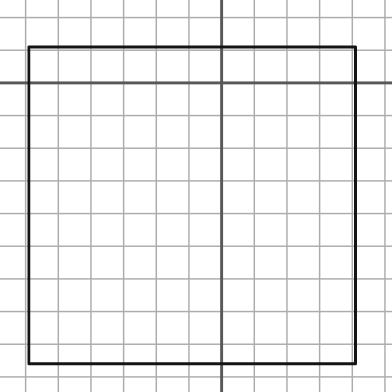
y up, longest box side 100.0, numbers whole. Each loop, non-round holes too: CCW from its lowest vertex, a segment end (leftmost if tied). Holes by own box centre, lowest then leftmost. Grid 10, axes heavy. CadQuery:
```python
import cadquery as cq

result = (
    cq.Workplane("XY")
    .moveTo(-59.0, -86.0)
    .lineTo(41.0, -86.0)
    .lineTo(41.0, 11.0)
    .lineTo(-59.0, 11.0)
    .close()
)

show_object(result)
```